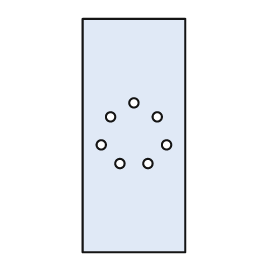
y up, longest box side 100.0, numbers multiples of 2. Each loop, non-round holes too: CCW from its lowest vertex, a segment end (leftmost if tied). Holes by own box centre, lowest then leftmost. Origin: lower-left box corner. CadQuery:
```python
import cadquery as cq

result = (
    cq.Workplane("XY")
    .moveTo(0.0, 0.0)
    .lineTo(44.0, 0.0)
    .lineTo(44.0, 100.0)
    .lineTo(0.0, 100.0)
    .close()
    .moveTo(16.0, 38.0)
    .circle(2.0)
    .moveTo(28.0, 38.0)
    .circle(2.0)
    .moveTo(8.0, 46.0)
    .circle(2.0)
    .moveTo(36.0, 46.0)
    .circle(2.0)
    .moveTo(12.0, 58.0)
    .circle(2.0)
    .moveTo(32.0, 58.0)
    .circle(2.0)
    .moveTo(22.0, 64.0)
    .circle(2.0)
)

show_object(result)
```